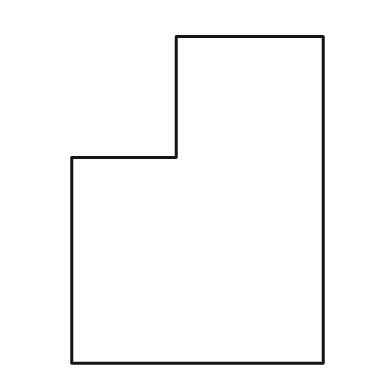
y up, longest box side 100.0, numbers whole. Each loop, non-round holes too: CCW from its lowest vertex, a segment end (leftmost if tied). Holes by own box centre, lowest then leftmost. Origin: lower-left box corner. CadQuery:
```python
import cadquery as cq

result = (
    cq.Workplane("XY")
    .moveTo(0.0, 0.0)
    .lineTo(77.0, 0.0)
    .lineTo(77.0, 100.0)
    .lineTo(32.0, 100.0)
    .lineTo(32.0, 63.0)
    .lineTo(0.0, 63.0)
    .close()
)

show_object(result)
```